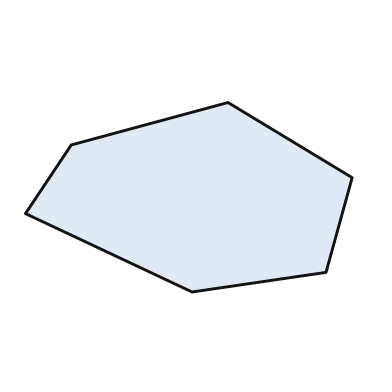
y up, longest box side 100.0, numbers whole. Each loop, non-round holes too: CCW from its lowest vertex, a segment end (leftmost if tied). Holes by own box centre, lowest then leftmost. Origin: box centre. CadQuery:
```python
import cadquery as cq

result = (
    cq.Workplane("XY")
    .moveTo(1.0, -29.0)
    .lineTo(42.0, -23.0)
    .lineTo(50.0, 6.0)
    .lineTo(12.0, 29.0)
    .lineTo(-36.0, 16.0)
    .lineTo(-50.0, -5.0)
    .close()
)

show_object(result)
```